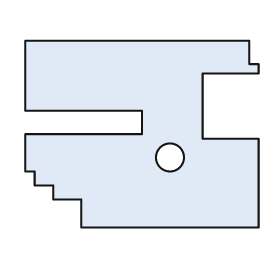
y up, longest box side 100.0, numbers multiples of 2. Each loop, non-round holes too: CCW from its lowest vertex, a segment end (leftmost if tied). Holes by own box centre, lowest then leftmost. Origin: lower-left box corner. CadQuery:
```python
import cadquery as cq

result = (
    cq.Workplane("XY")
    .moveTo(24.0, 0.0)
    .lineTo(100.0, 0.0)
    .lineTo(100.0, 38.0)
    .lineTo(76.0, 38.0)
    .lineTo(76.0, 66.0)
    .lineTo(100.0, 66.0)
    .lineTo(100.0, 70.0)
    .lineTo(96.0, 70.0)
    .lineTo(96.0, 80.0)
    .lineTo(0.0, 80.0)
    .lineTo(0.0, 50.0)
    .lineTo(50.0, 50.0)
    .lineTo(50.0, 40.0)
    .lineTo(0.0, 40.0)
    .lineTo(0.0, 24.0)
    .lineTo(4.0, 24.0)
    .lineTo(4.0, 18.0)
    .lineTo(12.0, 18.0)
    .lineTo(12.0, 12.0)
    .lineTo(24.0, 12.0)
    .close()
    .moveTo(62.0, 30.0)
    .circle(6.0)
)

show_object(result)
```